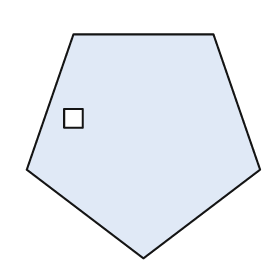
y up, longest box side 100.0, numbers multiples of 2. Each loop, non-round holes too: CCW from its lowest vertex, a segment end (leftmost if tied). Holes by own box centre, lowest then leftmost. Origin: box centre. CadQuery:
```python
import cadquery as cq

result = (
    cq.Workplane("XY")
    .moveTo(0.0, -48.0)
    .lineTo(50.0, -10.0)
    .lineTo(30.0, 48.0)
    .lineTo(-30.0, 48.0)
    .lineTo(-50.0, -10.0)
    .close()
    .moveTo(-34.0, 8.0)
    .lineTo(-26.0, 8.0)
    .lineTo(-26.0, 16.0)
    .lineTo(-34.0, 16.0)
    .close()
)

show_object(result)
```